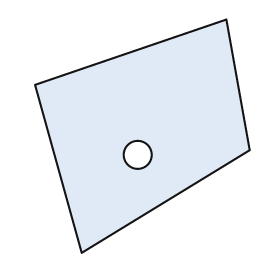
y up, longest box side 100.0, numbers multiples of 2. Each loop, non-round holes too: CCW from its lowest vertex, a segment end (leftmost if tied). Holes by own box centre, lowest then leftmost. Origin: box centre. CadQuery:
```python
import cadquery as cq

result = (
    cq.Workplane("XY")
    .moveTo(-26.0, -50.0)
    .lineTo(46.0, -6.0)
    .lineTo(36.0, 50.0)
    .lineTo(-46.0, 22.0)
    .close()
    .moveTo(-2.0, -8.0)
    .circle(6.0)
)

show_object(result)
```